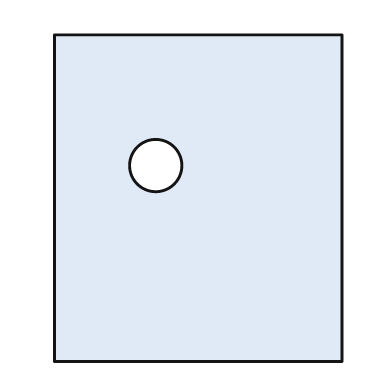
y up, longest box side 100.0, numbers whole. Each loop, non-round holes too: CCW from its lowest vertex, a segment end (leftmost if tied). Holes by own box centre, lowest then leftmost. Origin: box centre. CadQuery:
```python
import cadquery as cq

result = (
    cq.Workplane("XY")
    .moveTo(-44.0, -50.0)
    .lineTo(44.0, -50.0)
    .lineTo(44.0, 50.0)
    .lineTo(-44.0, 50.0)
    .close()
    .moveTo(-13.0, 10.0)
    .circle(8.0)
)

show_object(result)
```